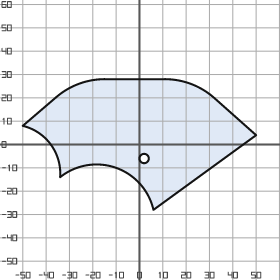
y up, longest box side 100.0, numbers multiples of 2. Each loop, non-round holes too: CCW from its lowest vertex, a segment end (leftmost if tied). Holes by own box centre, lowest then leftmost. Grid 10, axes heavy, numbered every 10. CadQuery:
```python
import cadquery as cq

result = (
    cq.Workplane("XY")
    .moveTo(6.0, -28.0)
    .lineTo(50.0, 4.0)
    .lineTo(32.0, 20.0)
    .threePointArc((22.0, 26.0), (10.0, 28.0))
    .lineTo(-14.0, 28.0)
    .threePointArc((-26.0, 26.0), (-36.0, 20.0))
    .lineTo(-50.0, 8.0)
    .threePointArc((-38.0, 0.0), (-34.0, -14.0))
    .threePointArc((-10.0, -10.0), (6.0, -28.0))
    .close()
    .moveTo(2.0, -6.0)
    .circle(2.0)
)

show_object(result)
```